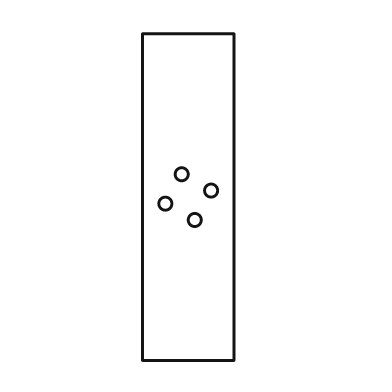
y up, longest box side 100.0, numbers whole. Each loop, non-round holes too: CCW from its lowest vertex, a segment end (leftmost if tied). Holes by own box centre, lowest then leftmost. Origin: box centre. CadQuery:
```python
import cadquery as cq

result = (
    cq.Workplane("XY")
    .moveTo(-14.0, -50.0)
    .lineTo(14.0, -50.0)
    .lineTo(14.0, 50.0)
    .lineTo(-14.0, 50.0)
    .close()
    .moveTo(2.0, -7.0)
    .circle(2.0)
    .moveTo(-7.0, -2.0)
    .circle(2.0)
    .moveTo(7.0, 2.0)
    .circle(2.0)
    .moveTo(-2.0, 7.0)
    .circle(2.0)
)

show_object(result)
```